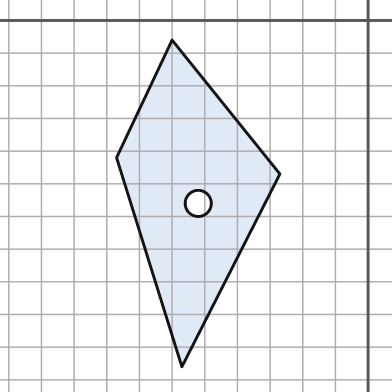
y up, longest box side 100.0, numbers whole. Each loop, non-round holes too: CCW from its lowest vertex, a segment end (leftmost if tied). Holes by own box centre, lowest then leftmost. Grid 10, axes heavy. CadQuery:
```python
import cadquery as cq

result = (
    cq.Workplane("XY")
    .moveTo(-57.0, -106.0)
    .lineTo(-27.0, -47.0)
    .lineTo(-60.0, -6.0)
    .lineTo(-77.0, -42.0)
    .close()
    .moveTo(-52.0, -56.0)
    .circle(4.0)
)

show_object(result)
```